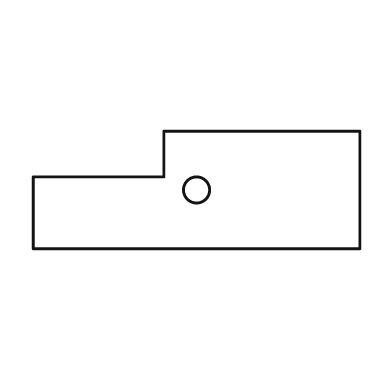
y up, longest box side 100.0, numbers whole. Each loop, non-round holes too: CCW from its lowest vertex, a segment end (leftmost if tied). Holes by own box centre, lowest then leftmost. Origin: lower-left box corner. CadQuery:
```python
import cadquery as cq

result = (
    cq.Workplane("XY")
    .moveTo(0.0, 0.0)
    .lineTo(100.0, 0.0)
    .lineTo(100.0, 36.0)
    .lineTo(40.0, 36.0)
    .lineTo(40.0, 22.0)
    .lineTo(0.0, 22.0)
    .close()
    .moveTo(50.0, 18.0)
    .circle(4.0)
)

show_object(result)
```